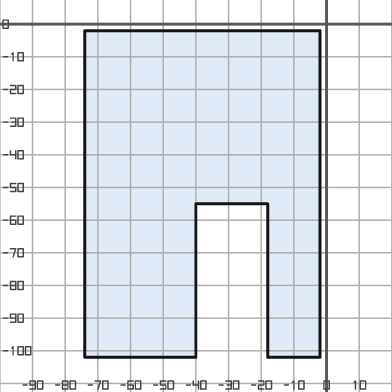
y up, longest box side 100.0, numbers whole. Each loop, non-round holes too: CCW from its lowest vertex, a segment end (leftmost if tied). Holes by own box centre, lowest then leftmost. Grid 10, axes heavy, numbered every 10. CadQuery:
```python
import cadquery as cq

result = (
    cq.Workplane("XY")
    .moveTo(-74.0, -102.0)
    .lineTo(-40.0, -102.0)
    .lineTo(-40.0, -55.0)
    .lineTo(-18.0, -55.0)
    .lineTo(-18.0, -102.0)
    .lineTo(-2.0, -102.0)
    .lineTo(-2.0, -2.0)
    .lineTo(-74.0, -2.0)
    .close()
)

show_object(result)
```